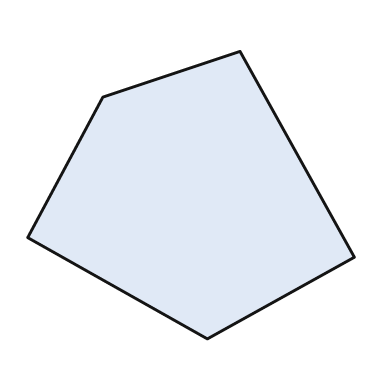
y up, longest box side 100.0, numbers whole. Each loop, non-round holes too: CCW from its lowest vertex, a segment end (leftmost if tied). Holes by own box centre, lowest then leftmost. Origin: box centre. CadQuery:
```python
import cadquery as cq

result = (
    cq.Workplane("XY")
    .moveTo(5.0, -44.0)
    .lineTo(50.0, -19.0)
    .lineTo(15.0, 44.0)
    .lineTo(-27.0, 30.0)
    .lineTo(-50.0, -13.0)
    .close()
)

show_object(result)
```